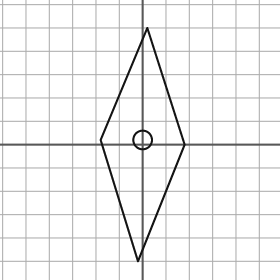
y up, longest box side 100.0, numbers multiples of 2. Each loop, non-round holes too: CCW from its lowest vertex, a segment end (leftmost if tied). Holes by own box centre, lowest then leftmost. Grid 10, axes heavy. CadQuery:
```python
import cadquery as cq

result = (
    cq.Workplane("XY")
    .moveTo(-2.0, -50.0)
    .lineTo(18.0, 0.0)
    .lineTo(2.0, 50.0)
    .lineTo(-18.0, 2.0)
    .close()
    .moveTo(0.0, 2.0)
    .circle(4.0)
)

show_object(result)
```